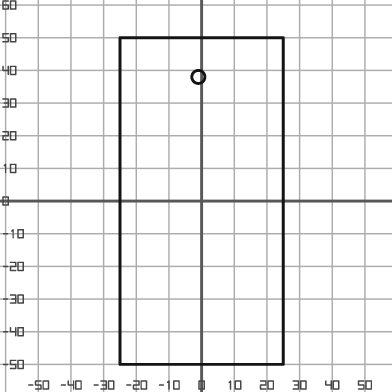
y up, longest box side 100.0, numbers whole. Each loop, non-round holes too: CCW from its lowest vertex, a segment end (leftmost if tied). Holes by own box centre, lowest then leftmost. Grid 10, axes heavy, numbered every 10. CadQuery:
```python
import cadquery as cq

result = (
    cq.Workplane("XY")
    .moveTo(-25.0, -50.0)
    .lineTo(25.0, -50.0)
    .lineTo(25.0, 50.0)
    .lineTo(-25.0, 50.0)
    .close()
    .moveTo(-1.0, 38.0)
    .circle(2.0)
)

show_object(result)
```